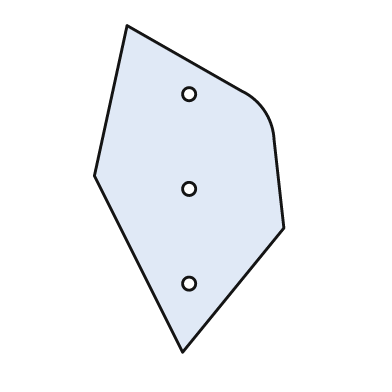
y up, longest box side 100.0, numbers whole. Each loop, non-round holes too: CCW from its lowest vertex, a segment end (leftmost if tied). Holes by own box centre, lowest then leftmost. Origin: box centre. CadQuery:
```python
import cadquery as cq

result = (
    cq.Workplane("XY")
    .moveTo(-2.0, -50.0)
    .lineTo(29.0, -12.0)
    .lineTo(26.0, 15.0)
    .threePointArc((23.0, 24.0), (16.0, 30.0))
    .lineTo(-19.0, 50.0)
    .lineTo(-29.0, 4.0)
    .close()
    .moveTo(0.0, -29.0)
    .circle(2.0)
    .moveTo(0.0, 0.0)
    .circle(2.0)
    .moveTo(0.0, 29.0)
    .circle(2.0)
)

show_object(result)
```